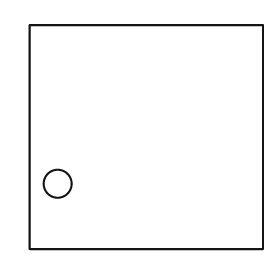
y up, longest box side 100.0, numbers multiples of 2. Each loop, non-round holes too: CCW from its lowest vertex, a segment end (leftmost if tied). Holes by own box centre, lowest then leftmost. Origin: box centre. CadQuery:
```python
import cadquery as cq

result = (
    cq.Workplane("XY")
    .moveTo(-50.0, -48.0)
    .lineTo(50.0, -48.0)
    .lineTo(50.0, 48.0)
    .lineTo(-50.0, 48.0)
    .close()
    .moveTo(-38.0, -20.0)
    .circle(6.0)
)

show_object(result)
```